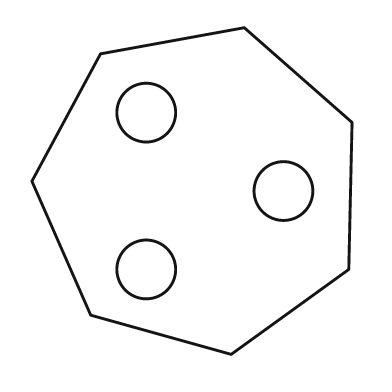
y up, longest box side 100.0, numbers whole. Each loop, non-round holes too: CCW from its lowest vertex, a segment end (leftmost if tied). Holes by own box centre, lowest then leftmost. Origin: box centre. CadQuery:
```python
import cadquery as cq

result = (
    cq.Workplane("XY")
    .moveTo(12.0, -50.0)
    .lineTo(48.0, -24.0)
    .lineTo(49.0, 21.0)
    .lineTo(16.0, 50.0)
    .lineTo(-28.0, 42.0)
    .lineTo(-49.0, 3.0)
    .lineTo(-31.0, -38.0)
    .close()
    .moveTo(-14.0, -24.0)
    .circle(9.0)
    .moveTo(28.0, 0.0)
    .circle(9.0)
    .moveTo(-14.0, 24.0)
    .circle(9.0)
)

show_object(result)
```